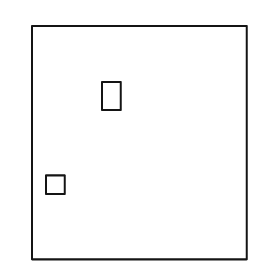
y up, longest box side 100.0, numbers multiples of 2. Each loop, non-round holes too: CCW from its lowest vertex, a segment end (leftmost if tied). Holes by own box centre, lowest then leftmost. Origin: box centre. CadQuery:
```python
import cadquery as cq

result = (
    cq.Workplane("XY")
    .moveTo(-46.0, -50.0)
    .lineTo(46.0, -50.0)
    .lineTo(46.0, 50.0)
    .lineTo(-46.0, 50.0)
    .close()
    .moveTo(-40.0, -22.0)
    .lineTo(-32.0, -22.0)
    .lineTo(-32.0, -14.0)
    .lineTo(-40.0, -14.0)
    .close()
    .moveTo(-16.0, 14.0)
    .lineTo(-8.0, 14.0)
    .lineTo(-8.0, 26.0)
    .lineTo(-16.0, 26.0)
    .close()
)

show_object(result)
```